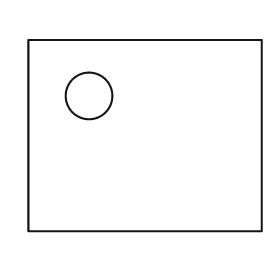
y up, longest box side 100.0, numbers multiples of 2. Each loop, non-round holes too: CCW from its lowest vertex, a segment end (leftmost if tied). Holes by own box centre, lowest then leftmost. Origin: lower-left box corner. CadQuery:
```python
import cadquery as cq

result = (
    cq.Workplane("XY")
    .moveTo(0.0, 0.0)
    .lineTo(100.0, 0.0)
    .lineTo(100.0, 82.0)
    .lineTo(0.0, 82.0)
    .close()
    .moveTo(26.0, 58.0)
    .circle(10.0)
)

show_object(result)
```